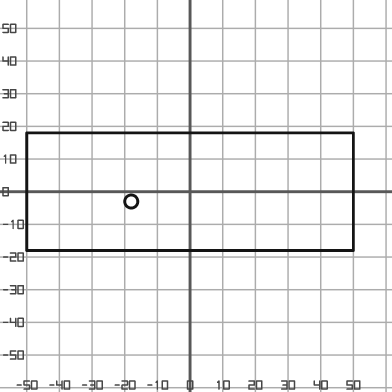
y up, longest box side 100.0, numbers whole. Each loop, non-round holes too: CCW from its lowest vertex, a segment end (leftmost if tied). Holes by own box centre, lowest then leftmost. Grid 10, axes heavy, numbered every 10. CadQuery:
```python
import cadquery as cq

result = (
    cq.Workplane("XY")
    .moveTo(-50.0, -18.0)
    .lineTo(50.0, -18.0)
    .lineTo(50.0, 18.0)
    .lineTo(-50.0, 18.0)
    .close()
    .moveTo(-18.0, -3.0)
    .circle(2.0)
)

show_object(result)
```